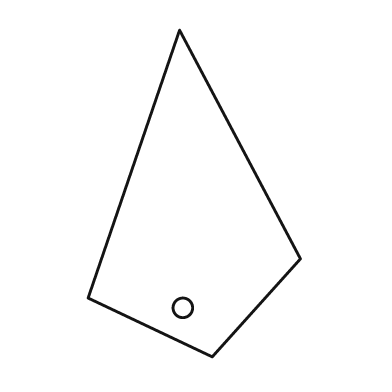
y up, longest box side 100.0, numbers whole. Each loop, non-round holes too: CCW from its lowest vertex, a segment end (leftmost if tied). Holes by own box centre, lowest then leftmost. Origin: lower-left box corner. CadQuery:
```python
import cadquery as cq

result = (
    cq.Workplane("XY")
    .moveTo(38.0, 0.0)
    .lineTo(65.0, 30.0)
    .lineTo(28.0, 100.0)
    .lineTo(0.0, 18.0)
    .close()
    .moveTo(29.0, 15.0)
    .circle(3.0)
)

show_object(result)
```